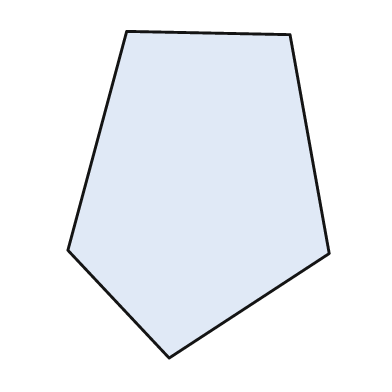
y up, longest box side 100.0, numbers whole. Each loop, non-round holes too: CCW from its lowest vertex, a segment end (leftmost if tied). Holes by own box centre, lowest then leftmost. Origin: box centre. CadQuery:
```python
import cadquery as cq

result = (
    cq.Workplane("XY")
    .moveTo(-9.0, -50.0)
    .lineTo(40.0, -18.0)
    .lineTo(28.0, 49.0)
    .lineTo(-22.0, 50.0)
    .lineTo(-40.0, -17.0)
    .close()
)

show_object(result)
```